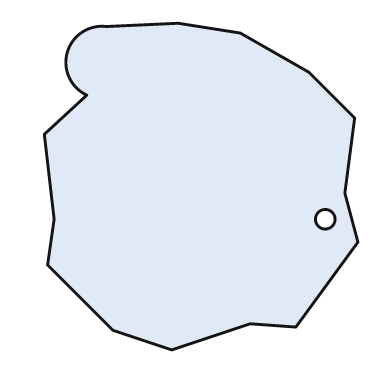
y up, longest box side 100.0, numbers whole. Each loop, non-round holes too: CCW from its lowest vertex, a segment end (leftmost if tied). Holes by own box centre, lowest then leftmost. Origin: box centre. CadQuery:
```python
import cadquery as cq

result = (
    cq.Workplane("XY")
    .moveTo(-9.0, -50.0)
    .lineTo(15.0, -42.0)
    .lineTo(29.0, -43.0)
    .lineTo(48.0, -17.0)
    .lineTo(44.0, -2.0)
    .lineTo(47.0, 21.0)
    .lineTo(33.0, 35.0)
    .lineTo(12.0, 47.0)
    .lineTo(-7.0, 50.0)
    .lineTo(-29.0, 49.0)
    .threePointArc((-41.0, 41.0), (-35.0, 28.0))
    .lineTo(-48.0, 16.0)
    .lineTo(-45.0, -10.0)
    .lineTo(-47.0, -24.0)
    .lineTo(-27.0, -44.0)
    .close()
    .moveTo(38.0, -10.0)
    .circle(3.0)
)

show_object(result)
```